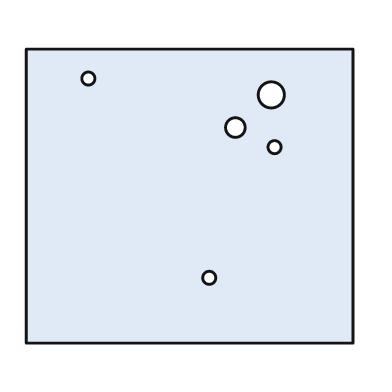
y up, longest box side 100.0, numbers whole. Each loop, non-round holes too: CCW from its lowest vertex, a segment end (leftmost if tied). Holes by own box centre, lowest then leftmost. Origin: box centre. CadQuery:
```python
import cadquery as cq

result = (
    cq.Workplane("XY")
    .moveTo(-50.0, -45.0)
    .lineTo(50.0, -45.0)
    .lineTo(50.0, 45.0)
    .lineTo(-50.0, 45.0)
    .close()
    .moveTo(6.0, -25.0)
    .circle(2.0)
    .moveTo(26.0, 15.0)
    .circle(2.0)
    .moveTo(14.0, 21.0)
    .circle(3.0)
    .moveTo(25.0, 31.0)
    .circle(4.0)
    .moveTo(-31.0, 36.0)
    .circle(2.0)
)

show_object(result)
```